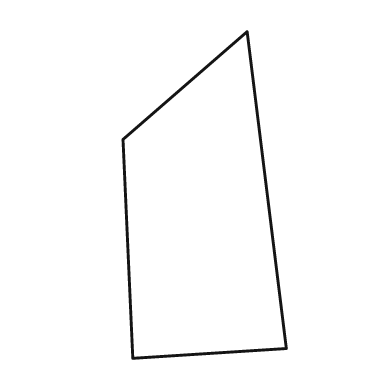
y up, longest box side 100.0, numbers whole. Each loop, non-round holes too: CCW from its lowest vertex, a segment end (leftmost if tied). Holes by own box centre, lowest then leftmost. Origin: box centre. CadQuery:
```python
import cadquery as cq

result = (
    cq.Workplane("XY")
    .moveTo(-22.0, -50.0)
    .lineTo(25.0, -47.0)
    .lineTo(13.0, 50.0)
    .lineTo(-25.0, 17.0)
    .close()
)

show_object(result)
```